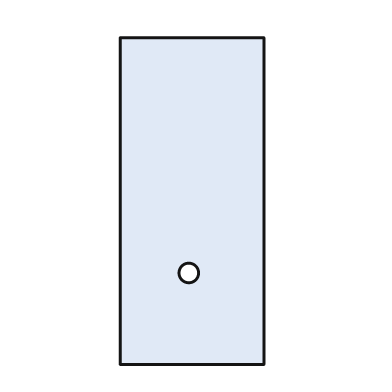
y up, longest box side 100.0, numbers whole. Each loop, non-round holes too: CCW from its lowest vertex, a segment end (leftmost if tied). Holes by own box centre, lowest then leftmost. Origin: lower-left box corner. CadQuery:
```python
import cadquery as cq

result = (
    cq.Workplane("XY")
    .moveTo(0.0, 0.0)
    .lineTo(44.0, 0.0)
    .lineTo(44.0, 100.0)
    .lineTo(0.0, 100.0)
    .close()
    .moveTo(21.0, 28.0)
    .circle(3.0)
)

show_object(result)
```